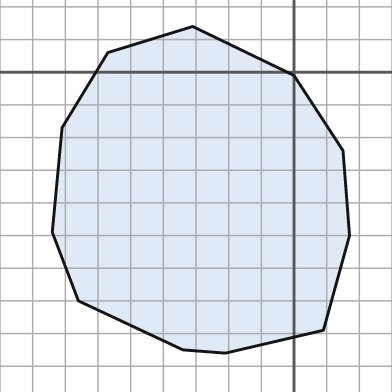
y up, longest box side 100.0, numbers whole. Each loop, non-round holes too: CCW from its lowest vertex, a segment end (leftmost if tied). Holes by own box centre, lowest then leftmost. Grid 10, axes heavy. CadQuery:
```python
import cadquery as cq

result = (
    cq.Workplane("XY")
    .moveTo(-21.0, -86.0)
    .lineTo(9.0, -79.0)
    .lineTo(17.0, -50.0)
    .lineTo(15.0, -24.0)
    .lineTo(0.0, -1.0)
    .lineTo(-31.0, 14.0)
    .lineTo(-57.0, 6.0)
    .lineTo(-71.0, -17.0)
    .lineTo(-74.0, -49.0)
    .lineTo(-66.0, -70.0)
    .lineTo(-34.0, -85.0)
    .close()
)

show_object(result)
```